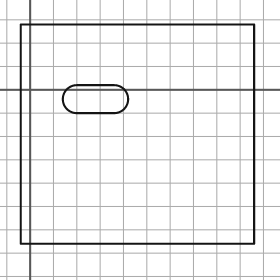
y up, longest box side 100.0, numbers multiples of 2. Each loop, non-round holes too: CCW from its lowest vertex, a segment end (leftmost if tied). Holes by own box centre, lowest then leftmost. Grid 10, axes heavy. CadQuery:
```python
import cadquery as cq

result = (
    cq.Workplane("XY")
    .moveTo(-4.0, -66.0)
    .lineTo(96.0, -66.0)
    .lineTo(96.0, 28.0)
    .lineTo(-4.0, 28.0)
    .close()
    .moveTo(20.0, -10.0)
    .lineTo(36.0, -10.0)
    .threePointArc((42.0, -4.0), (36.0, 2.0))
    .lineTo(20.0, 2.0)
    .threePointArc((14.0, -4.0), (20.0, -10.0))
    .close()
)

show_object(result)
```